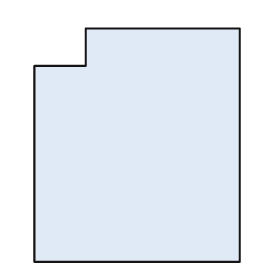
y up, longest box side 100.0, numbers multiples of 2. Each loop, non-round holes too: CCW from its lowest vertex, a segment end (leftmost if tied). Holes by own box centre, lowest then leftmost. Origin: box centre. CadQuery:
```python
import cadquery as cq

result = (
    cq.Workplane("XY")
    .moveTo(-44.0, -50.0)
    .lineTo(44.0, -50.0)
    .lineTo(44.0, 50.0)
    .lineTo(-22.0, 50.0)
    .lineTo(-22.0, 34.0)
    .lineTo(-44.0, 34.0)
    .close()
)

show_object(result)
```